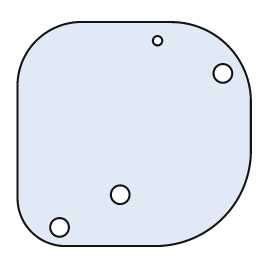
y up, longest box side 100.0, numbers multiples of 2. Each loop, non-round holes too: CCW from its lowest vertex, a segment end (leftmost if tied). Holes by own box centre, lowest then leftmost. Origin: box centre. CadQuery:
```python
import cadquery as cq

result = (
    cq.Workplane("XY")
    .moveTo(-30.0, -48.0)
    .lineTo(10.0, -48.0)
    .threePointArc((38.0, -36.0), (50.0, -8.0))
    .lineTo(50.0, 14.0)
    .threePointArc((40.0, 38.0), (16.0, 48.0))
    .lineTo(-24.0, 48.0)
    .threePointArc((-42.0, 40.0), (-50.0, 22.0))
    .lineTo(-50.0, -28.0)
    .threePointArc((-44.0, -42.0), (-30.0, -48.0))
    .close()
    .moveTo(-32.0, -40.0)
    .circle(4.0)
    .moveTo(-6.0, -26.0)
    .circle(4.0)
    .moveTo(38.0, 26.0)
    .circle(4.0)
    .moveTo(10.0, 40.0)
    .circle(2.0)
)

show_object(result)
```